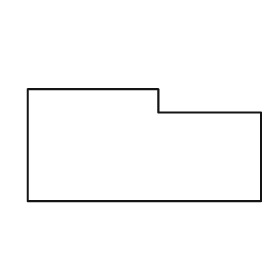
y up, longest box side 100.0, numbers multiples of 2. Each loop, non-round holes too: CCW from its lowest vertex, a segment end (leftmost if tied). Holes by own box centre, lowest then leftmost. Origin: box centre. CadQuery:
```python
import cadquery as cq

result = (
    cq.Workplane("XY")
    .moveTo(-50.0, -24.0)
    .lineTo(50.0, -24.0)
    .lineTo(50.0, 14.0)
    .lineTo(6.0, 14.0)
    .lineTo(6.0, 24.0)
    .lineTo(-50.0, 24.0)
    .close()
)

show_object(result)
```